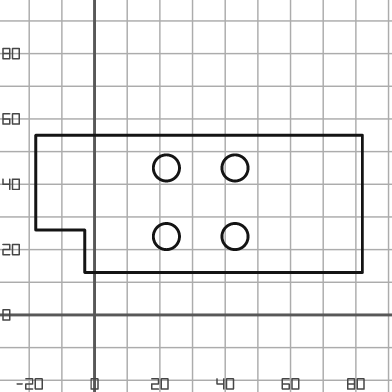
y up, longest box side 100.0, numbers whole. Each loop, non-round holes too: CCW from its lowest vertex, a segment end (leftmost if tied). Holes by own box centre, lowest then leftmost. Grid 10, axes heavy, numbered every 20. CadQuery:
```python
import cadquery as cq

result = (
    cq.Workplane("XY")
    .moveTo(-3.0, 13.0)
    .lineTo(82.0, 13.0)
    .lineTo(82.0, 55.0)
    .lineTo(-18.0, 55.0)
    .lineTo(-18.0, 26.0)
    .lineTo(-3.0, 26.0)
    .close()
    .moveTo(22.0, 24.0)
    .circle(4.0)
    .moveTo(43.0, 24.0)
    .circle(4.0)
    .moveTo(22.0, 45.0)
    .circle(4.0)
    .moveTo(43.0, 45.0)
    .circle(4.0)
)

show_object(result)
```